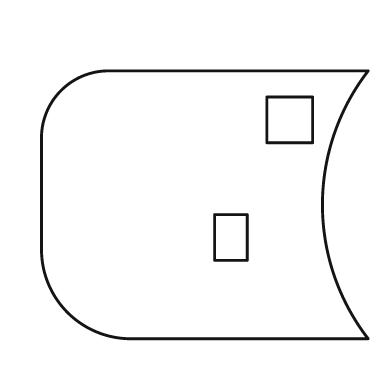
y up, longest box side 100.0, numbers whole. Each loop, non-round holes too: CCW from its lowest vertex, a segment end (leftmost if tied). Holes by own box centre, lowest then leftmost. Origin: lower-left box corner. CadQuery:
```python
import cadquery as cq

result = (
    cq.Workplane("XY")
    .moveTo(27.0, 0.0)
    .lineTo(100.0, 0.0)
    .threePointArc((86.0, 41.0), (100.0, 82.0))
    .lineTo(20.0, 82.0)
    .threePointArc((6.0, 76.0), (0.0, 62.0))
    .lineTo(0.0, 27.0)
    .threePointArc((8.0, 8.0), (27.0, 0.0))
    .close()
    .moveTo(53.0, 24.0)
    .lineTo(63.0, 24.0)
    .lineTo(63.0, 38.0)
    .lineTo(53.0, 38.0)
    .close()
    .moveTo(69.0, 60.0)
    .lineTo(83.0, 60.0)
    .lineTo(83.0, 74.0)
    .lineTo(69.0, 74.0)
    .close()
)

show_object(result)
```